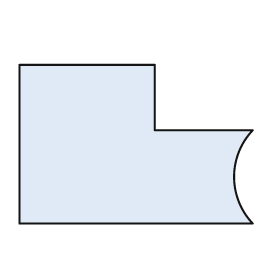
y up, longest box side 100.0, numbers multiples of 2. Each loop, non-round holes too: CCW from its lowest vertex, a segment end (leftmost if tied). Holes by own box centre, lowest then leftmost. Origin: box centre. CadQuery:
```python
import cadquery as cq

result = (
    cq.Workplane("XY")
    .moveTo(-50.0, -34.0)
    .lineTo(50.0, -34.0)
    .threePointArc((42.0, -14.0), (50.0, 6.0))
    .lineTo(8.0, 6.0)
    .lineTo(8.0, 34.0)
    .lineTo(-50.0, 34.0)
    .close()
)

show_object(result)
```